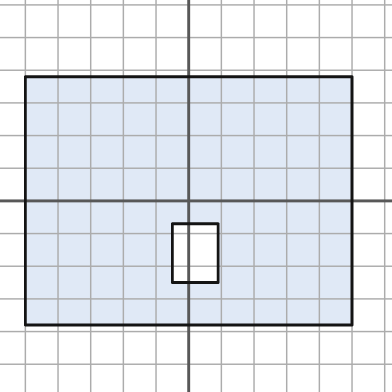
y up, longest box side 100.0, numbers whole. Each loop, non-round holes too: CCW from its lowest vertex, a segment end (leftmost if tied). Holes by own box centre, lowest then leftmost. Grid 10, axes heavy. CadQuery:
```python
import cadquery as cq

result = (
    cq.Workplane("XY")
    .moveTo(-50.0, -38.0)
    .lineTo(50.0, -38.0)
    .lineTo(50.0, 38.0)
    .lineTo(-50.0, 38.0)
    .close()
    .moveTo(-5.0, -25.0)
    .lineTo(9.0, -25.0)
    .lineTo(9.0, -7.0)
    .lineTo(-5.0, -7.0)
    .close()
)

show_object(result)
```